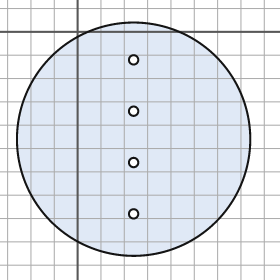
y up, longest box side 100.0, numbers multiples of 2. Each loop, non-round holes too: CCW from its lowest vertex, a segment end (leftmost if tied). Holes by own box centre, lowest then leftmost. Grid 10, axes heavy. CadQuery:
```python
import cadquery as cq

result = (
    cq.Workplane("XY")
    .moveTo(24.0, -46.0)
    .circle(50.0)
    .moveTo(24.0, -78.0)
    .circle(2.0)
    .moveTo(24.0, -56.0)
    .circle(2.0)
    .moveTo(24.0, -34.0)
    .circle(2.0)
    .moveTo(24.0, -12.0)
    .circle(2.0)
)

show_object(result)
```